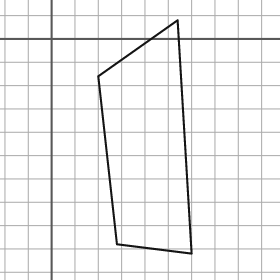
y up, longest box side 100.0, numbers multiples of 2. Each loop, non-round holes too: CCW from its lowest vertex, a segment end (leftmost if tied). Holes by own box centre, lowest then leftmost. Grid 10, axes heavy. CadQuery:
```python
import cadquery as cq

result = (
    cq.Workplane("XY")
    .moveTo(60.0, -92.0)
    .lineTo(54.0, 8.0)
    .lineTo(20.0, -16.0)
    .lineTo(28.0, -88.0)
    .close()
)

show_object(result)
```